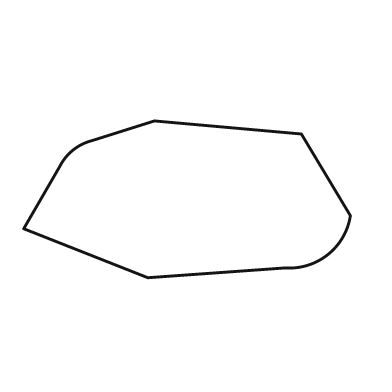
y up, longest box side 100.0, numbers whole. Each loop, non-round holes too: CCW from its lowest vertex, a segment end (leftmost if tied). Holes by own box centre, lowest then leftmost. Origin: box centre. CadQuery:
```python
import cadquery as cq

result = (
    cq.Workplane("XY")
    .moveTo(-12.0, -24.0)
    .lineTo(30.0, -21.0)
    .threePointArc((43.0, -17.0), (50.0, -5.0))
    .lineTo(35.0, 20.0)
    .lineTo(-10.0, 24.0)
    .lineTo(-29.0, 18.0)
    .threePointArc((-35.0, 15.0), (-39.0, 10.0))
    .lineTo(-50.0, -9.0)
    .close()
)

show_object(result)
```